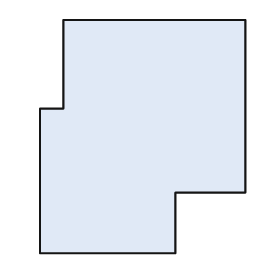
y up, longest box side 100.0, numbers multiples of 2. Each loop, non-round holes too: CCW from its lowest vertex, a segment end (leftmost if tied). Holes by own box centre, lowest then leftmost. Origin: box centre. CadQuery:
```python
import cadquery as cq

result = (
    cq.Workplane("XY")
    .moveTo(-44.0, -50.0)
    .lineTo(14.0, -50.0)
    .lineTo(14.0, -24.0)
    .lineTo(44.0, -24.0)
    .lineTo(44.0, 50.0)
    .lineTo(-34.0, 50.0)
    .lineTo(-34.0, 12.0)
    .lineTo(-44.0, 12.0)
    .close()
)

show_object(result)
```